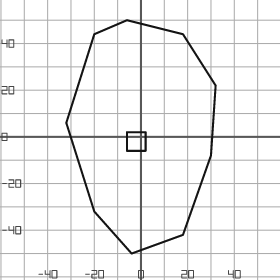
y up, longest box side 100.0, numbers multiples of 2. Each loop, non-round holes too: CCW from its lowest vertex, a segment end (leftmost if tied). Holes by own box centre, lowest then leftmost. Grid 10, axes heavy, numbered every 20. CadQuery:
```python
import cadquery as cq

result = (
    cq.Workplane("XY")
    .moveTo(-4.0, -50.0)
    .lineTo(18.0, -42.0)
    .lineTo(30.0, -8.0)
    .lineTo(32.0, 22.0)
    .lineTo(18.0, 44.0)
    .lineTo(-6.0, 50.0)
    .lineTo(-20.0, 44.0)
    .lineTo(-32.0, 6.0)
    .lineTo(-20.0, -32.0)
    .close()
    .moveTo(-6.0, -6.0)
    .lineTo(2.0, -6.0)
    .lineTo(2.0, 2.0)
    .lineTo(-6.0, 2.0)
    .close()
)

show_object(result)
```